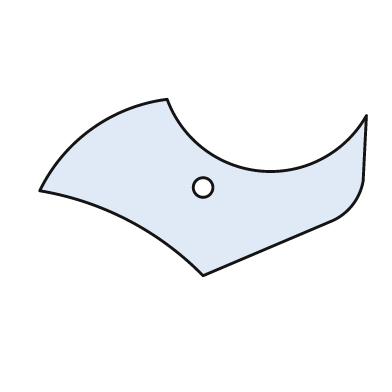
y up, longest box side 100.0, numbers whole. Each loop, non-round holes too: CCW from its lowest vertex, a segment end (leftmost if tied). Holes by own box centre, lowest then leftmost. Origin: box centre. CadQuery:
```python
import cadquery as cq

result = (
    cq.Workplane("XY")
    .moveTo(0.0, -27.0)
    .lineTo(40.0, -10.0)
    .threePointArc((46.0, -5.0), (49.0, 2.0))
    .lineTo(50.0, 22.0)
    .threePointArc((18.0, 5.0), (-11.0, 27.0))
    .threePointArc((-34.0, 18.0), (-50.0, -1.0))
    .threePointArc((-23.0, -10.0), (0.0, -27.0))
    .close()
    .moveTo(0.0, 0.0)
    .circle(3.0)
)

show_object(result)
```